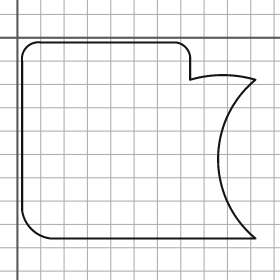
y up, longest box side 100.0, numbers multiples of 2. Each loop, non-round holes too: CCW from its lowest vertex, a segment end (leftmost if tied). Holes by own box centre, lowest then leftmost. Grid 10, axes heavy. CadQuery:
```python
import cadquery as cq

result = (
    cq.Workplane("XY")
    .moveTo(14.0, -86.0)
    .lineTo(102.0, -86.0)
    .threePointArc((86.0, -52.0), (102.0, -18.0))
    .threePointArc((88.0, -16.0), (74.0, -18.0))
    .lineTo(74.0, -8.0)
    .threePointArc((72.0, -4.0), (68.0, -2.0))
    .lineTo(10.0, -2.0)
    .threePointArc((4.0, -4.0), (2.0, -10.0))
    .lineTo(2.0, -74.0)
    .threePointArc((6.0, -82.0), (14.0, -86.0))
    .close()
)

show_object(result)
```